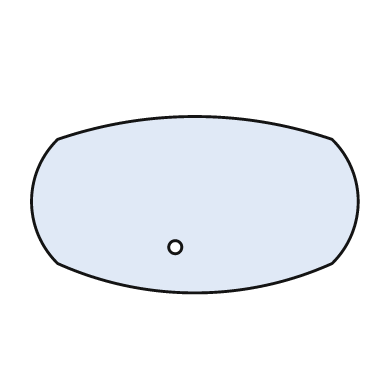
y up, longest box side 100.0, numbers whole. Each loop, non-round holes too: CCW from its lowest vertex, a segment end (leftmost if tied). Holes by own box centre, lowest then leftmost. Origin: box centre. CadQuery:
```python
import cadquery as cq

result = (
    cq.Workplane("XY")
    .moveTo(-42.0, -18.0)
    .threePointArc((0.0, -27.0), (42.0, -18.0))
    .threePointArc((50.0, 1.0), (42.0, 20.0))
    .threePointArc((0.0, 27.0), (-42.0, 20.0))
    .threePointArc((-50.0, 1.0), (-42.0, -18.0))
    .close()
    .moveTo(-6.0, -13.0)
    .circle(2.0)
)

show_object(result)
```